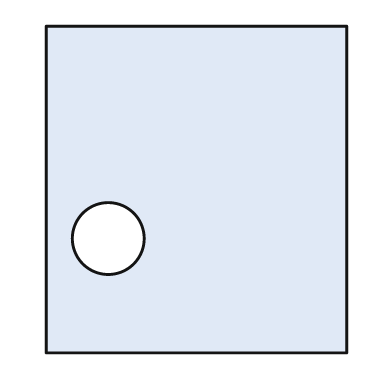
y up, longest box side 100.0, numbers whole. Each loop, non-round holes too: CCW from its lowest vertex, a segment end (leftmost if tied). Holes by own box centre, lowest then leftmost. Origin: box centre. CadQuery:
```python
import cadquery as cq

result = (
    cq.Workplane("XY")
    .moveTo(-46.0, -50.0)
    .lineTo(46.0, -50.0)
    .lineTo(46.0, 50.0)
    .lineTo(-46.0, 50.0)
    .close()
    .moveTo(-27.0, -15.0)
    .circle(11.0)
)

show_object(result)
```